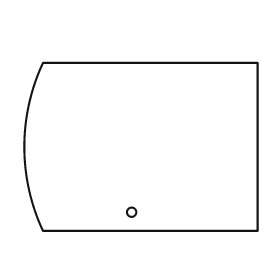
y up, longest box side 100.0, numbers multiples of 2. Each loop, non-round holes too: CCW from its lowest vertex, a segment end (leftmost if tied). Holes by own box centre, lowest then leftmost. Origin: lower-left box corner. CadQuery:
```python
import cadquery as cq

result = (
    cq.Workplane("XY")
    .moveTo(8.0, 0.0)
    .lineTo(100.0, 0.0)
    .lineTo(100.0, 72.0)
    .lineTo(8.0, 72.0)
    .threePointArc((0.0, 36.0), (8.0, 0.0))
    .close()
    .moveTo(46.0, 8.0)
    .circle(2.0)
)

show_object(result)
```